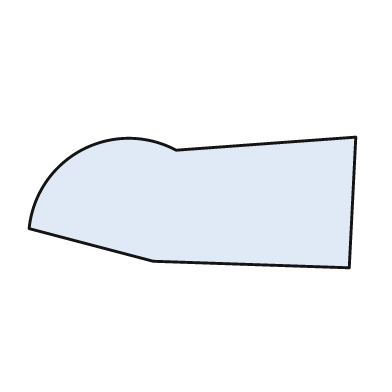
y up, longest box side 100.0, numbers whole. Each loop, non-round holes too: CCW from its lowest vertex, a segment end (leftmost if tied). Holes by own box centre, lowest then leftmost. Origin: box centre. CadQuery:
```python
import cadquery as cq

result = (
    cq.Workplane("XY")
    .moveTo(48.0, -20.0)
    .lineTo(50.0, 20.0)
    .lineTo(-5.0, 16.0)
    .threePointArc((-34.0, 16.0), (-50.0, -8.0))
    .lineTo(-12.0, -18.0)
    .close()
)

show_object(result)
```